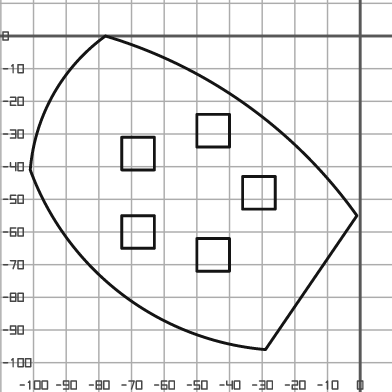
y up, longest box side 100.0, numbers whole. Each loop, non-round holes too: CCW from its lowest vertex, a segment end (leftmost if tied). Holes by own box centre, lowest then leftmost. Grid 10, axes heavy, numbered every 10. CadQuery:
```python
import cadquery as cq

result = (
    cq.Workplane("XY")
    .moveTo(-29.0, -96.0)
    .lineTo(-1.0, -55.0)
    .threePointArc((-35.0, -21.0), (-78.0, 0.0))
    .threePointArc((-94.0, -18.0), (-101.0, -41.0))
    .threePointArc((-73.0, -79.0), (-29.0, -96.0))
    .close()
    .moveTo(-50.0, -72.0)
    .lineTo(-40.0, -72.0)
    .lineTo(-40.0, -62.0)
    .lineTo(-50.0, -62.0)
    .close()
    .moveTo(-73.0, -65.0)
    .lineTo(-63.0, -65.0)
    .lineTo(-63.0, -55.0)
    .lineTo(-73.0, -55.0)
    .close()
    .moveTo(-36.0, -53.0)
    .lineTo(-26.0, -53.0)
    .lineTo(-26.0, -43.0)
    .lineTo(-36.0, -43.0)
    .close()
    .moveTo(-73.0, -41.0)
    .lineTo(-63.0, -41.0)
    .lineTo(-63.0, -31.0)
    .lineTo(-73.0, -31.0)
    .close()
    .moveTo(-50.0, -34.0)
    .lineTo(-40.0, -34.0)
    .lineTo(-40.0, -24.0)
    .lineTo(-50.0, -24.0)
    .close()
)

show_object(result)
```